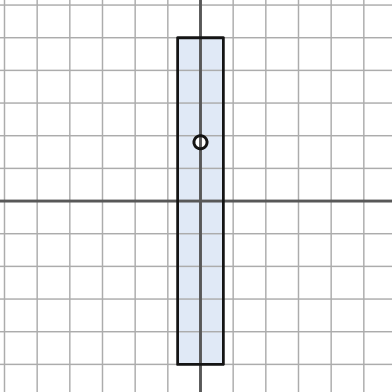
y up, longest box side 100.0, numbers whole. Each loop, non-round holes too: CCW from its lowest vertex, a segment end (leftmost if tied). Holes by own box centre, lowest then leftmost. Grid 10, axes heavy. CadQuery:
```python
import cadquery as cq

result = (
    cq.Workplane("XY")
    .moveTo(-7.0, -50.0)
    .lineTo(7.0, -50.0)
    .lineTo(7.0, 50.0)
    .lineTo(-7.0, 50.0)
    .close()
    .moveTo(0.0, 18.0)
    .circle(2.0)
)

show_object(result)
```